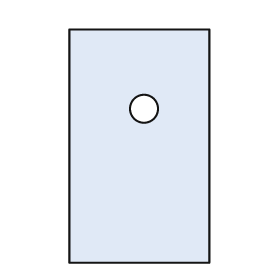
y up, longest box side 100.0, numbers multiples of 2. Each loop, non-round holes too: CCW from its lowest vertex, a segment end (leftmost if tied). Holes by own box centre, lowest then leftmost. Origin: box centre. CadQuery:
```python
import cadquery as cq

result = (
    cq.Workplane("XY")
    .moveTo(-30.0, -50.0)
    .lineTo(30.0, -50.0)
    .lineTo(30.0, 50.0)
    .lineTo(-30.0, 50.0)
    .close()
    .moveTo(2.0, 16.0)
    .circle(6.0)
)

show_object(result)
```